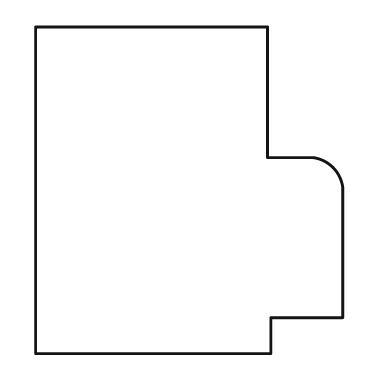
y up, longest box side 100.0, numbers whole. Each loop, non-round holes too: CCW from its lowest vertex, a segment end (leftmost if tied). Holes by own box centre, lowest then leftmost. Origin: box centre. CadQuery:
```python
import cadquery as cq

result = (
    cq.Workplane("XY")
    .moveTo(-47.0, -50.0)
    .lineTo(25.0, -50.0)
    .lineTo(25.0, -39.0)
    .lineTo(47.0, -39.0)
    .lineTo(47.0, 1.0)
    .threePointArc((44.0, 7.0), (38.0, 10.0))
    .lineTo(24.0, 10.0)
    .lineTo(24.0, 50.0)
    .lineTo(-47.0, 50.0)
    .close()
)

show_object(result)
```